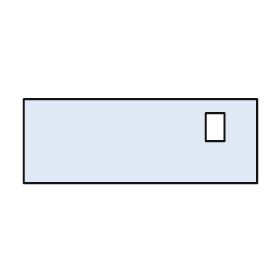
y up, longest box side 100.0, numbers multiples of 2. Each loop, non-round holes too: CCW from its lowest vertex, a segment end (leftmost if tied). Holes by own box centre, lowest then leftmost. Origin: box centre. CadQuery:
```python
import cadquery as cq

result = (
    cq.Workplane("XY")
    .moveTo(-50.0, -18.0)
    .lineTo(50.0, -18.0)
    .lineTo(50.0, 18.0)
    .lineTo(-50.0, 18.0)
    .close()
    .moveTo(28.0, 0.0)
    .lineTo(36.0, 0.0)
    .lineTo(36.0, 12.0)
    .lineTo(28.0, 12.0)
    .close()
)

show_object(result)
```